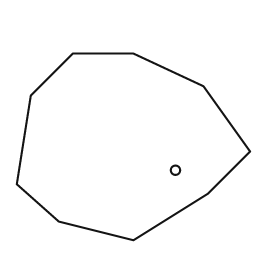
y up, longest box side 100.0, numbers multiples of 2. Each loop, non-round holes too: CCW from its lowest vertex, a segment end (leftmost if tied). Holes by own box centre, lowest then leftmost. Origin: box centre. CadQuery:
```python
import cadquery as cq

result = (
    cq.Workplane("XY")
    .moveTo(0.0, -40.0)
    .lineTo(32.0, -20.0)
    .lineTo(50.0, -2.0)
    .lineTo(30.0, 26.0)
    .lineTo(0.0, 40.0)
    .lineTo(-26.0, 40.0)
    .lineTo(-44.0, 22.0)
    .lineTo(-50.0, -16.0)
    .lineTo(-32.0, -32.0)
    .close()
    .moveTo(18.0, -10.0)
    .circle(2.0)
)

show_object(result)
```